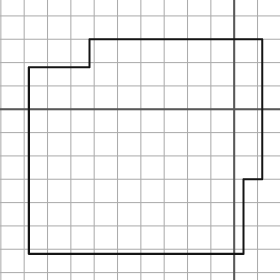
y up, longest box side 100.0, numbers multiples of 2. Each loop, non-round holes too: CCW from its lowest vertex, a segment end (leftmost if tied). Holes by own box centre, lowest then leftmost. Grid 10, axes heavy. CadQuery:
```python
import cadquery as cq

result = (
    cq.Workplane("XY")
    .moveTo(-88.0, -62.0)
    .lineTo(4.0, -62.0)
    .lineTo(4.0, -30.0)
    .lineTo(12.0, -30.0)
    .lineTo(12.0, 30.0)
    .lineTo(-62.0, 30.0)
    .lineTo(-62.0, 18.0)
    .lineTo(-88.0, 18.0)
    .close()
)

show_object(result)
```